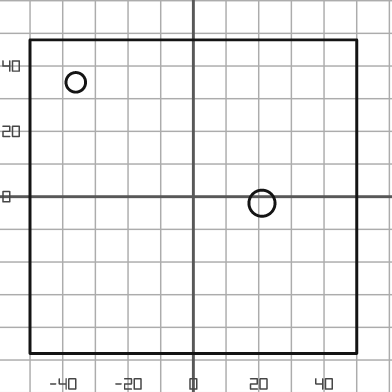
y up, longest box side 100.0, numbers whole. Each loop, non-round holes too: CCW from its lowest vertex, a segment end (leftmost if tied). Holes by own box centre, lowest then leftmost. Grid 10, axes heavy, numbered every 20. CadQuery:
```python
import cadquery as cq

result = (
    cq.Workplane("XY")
    .moveTo(-50.0, -48.0)
    .lineTo(50.0, -48.0)
    .lineTo(50.0, 48.0)
    .lineTo(-50.0, 48.0)
    .close()
    .moveTo(21.0, -2.0)
    .circle(4.0)
    .moveTo(-36.0, 35.0)
    .circle(3.0)
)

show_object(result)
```